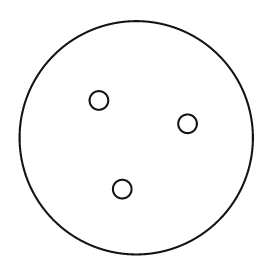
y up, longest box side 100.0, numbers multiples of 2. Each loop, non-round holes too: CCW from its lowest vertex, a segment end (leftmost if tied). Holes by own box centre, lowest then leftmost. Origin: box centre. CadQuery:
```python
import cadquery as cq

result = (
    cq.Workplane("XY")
    .moveTo(0.0, 0.0)
    .circle(50.0)
    .moveTo(-6.0, -22.0)
    .circle(4.0)
    .moveTo(22.0, 6.0)
    .circle(4.0)
    .moveTo(-16.0, 16.0)
    .circle(4.0)
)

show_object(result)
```